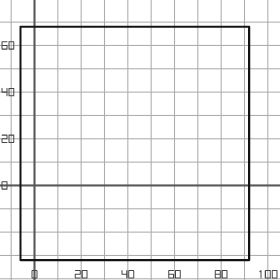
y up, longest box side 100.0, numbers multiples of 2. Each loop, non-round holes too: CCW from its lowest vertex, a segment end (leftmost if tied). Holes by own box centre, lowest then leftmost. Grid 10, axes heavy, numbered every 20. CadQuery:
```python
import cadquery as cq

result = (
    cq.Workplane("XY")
    .moveTo(-6.0, -32.0)
    .lineTo(92.0, -32.0)
    .lineTo(92.0, 68.0)
    .lineTo(-6.0, 68.0)
    .close()
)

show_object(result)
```